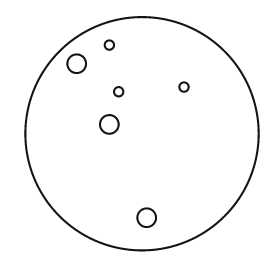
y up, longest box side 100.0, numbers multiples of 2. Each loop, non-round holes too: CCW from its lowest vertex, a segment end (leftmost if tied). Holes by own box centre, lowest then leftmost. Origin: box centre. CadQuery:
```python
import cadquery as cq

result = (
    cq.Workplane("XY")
    .moveTo(0.0, 0.0)
    .circle(50.0)
    .moveTo(2.0, -36.0)
    .circle(4.0)
    .moveTo(-14.0, 4.0)
    .circle(4.0)
    .moveTo(-10.0, 18.0)
    .circle(2.0)
    .moveTo(18.0, 20.0)
    .circle(2.0)
    .moveTo(-28.0, 30.0)
    .circle(4.0)
    .moveTo(-14.0, 38.0)
    .circle(2.0)
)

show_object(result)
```